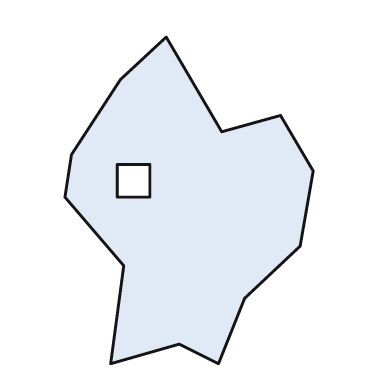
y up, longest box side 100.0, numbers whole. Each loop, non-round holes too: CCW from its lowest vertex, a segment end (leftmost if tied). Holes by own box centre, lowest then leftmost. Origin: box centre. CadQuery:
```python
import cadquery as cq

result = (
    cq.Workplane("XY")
    .moveTo(-24.0, -50.0)
    .lineTo(-3.0, -44.0)
    .lineTo(9.0, -50.0)
    .lineTo(17.0, -30.0)
    .lineTo(34.0, -14.0)
    .lineTo(38.0, 9.0)
    .lineTo(28.0, 26.0)
    .lineTo(10.0, 21.0)
    .lineTo(-7.0, 50.0)
    .lineTo(-21.0, 37.0)
    .lineTo(-36.0, 14.0)
    .lineTo(-38.0, 1.0)
    .lineTo(-20.0, -20.0)
    .close()
    .moveTo(-22.0, 1.0)
    .lineTo(-12.0, 1.0)
    .lineTo(-12.0, 11.0)
    .lineTo(-22.0, 11.0)
    .close()
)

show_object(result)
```